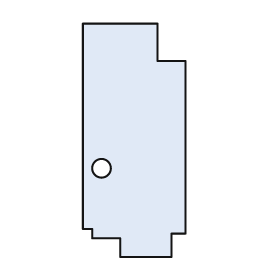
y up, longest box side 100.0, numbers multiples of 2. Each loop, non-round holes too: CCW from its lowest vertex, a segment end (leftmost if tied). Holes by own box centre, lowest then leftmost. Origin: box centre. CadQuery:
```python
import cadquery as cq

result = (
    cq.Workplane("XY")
    .moveTo(-6.0, -50.0)
    .lineTo(16.0, -50.0)
    .lineTo(16.0, -40.0)
    .lineTo(22.0, -40.0)
    .lineTo(22.0, 34.0)
    .lineTo(10.0, 34.0)
    .lineTo(10.0, 50.0)
    .lineTo(-22.0, 50.0)
    .lineTo(-22.0, -38.0)
    .lineTo(-18.0, -38.0)
    .lineTo(-18.0, -42.0)
    .lineTo(-6.0, -42.0)
    .close()
    .moveTo(-14.0, -12.0)
    .circle(4.0)
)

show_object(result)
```